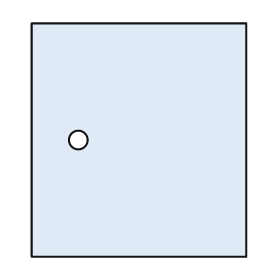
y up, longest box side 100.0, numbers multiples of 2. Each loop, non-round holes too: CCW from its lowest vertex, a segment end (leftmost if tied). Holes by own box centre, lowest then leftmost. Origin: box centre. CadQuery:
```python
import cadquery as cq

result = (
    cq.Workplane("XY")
    .moveTo(-46.0, -50.0)
    .lineTo(46.0, -50.0)
    .lineTo(46.0, 50.0)
    .lineTo(-46.0, 50.0)
    .close()
    .moveTo(-26.0, 0.0)
    .circle(4.0)
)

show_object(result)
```